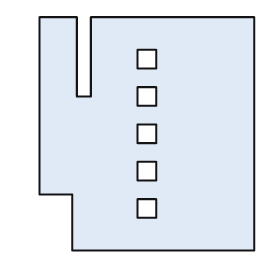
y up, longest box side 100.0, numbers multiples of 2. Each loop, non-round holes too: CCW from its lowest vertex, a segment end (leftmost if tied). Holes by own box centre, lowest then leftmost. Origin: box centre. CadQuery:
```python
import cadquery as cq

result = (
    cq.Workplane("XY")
    .moveTo(-32.0, -50.0)
    .lineTo(46.0, -50.0)
    .lineTo(46.0, 50.0)
    .lineTo(-24.0, 50.0)
    .lineTo(-24.0, 16.0)
    .lineTo(-30.0, 16.0)
    .lineTo(-30.0, 50.0)
    .lineTo(-46.0, 50.0)
    .lineTo(-46.0, -26.0)
    .lineTo(-32.0, -26.0)
    .close()
    .moveTo(-4.0, -36.0)
    .lineTo(4.0, -36.0)
    .lineTo(4.0, -28.0)
    .lineTo(-4.0, -28.0)
    .close()
    .moveTo(-4.0, -20.0)
    .lineTo(4.0, -20.0)
    .lineTo(4.0, -12.0)
    .lineTo(-4.0, -12.0)
    .close()
    .moveTo(-4.0, -4.0)
    .lineTo(4.0, -4.0)
    .lineTo(4.0, 4.0)
    .lineTo(-4.0, 4.0)
    .close()
    .moveTo(-4.0, 12.0)
    .lineTo(4.0, 12.0)
    .lineTo(4.0, 20.0)
    .lineTo(-4.0, 20.0)
    .close()
    .moveTo(-4.0, 28.0)
    .lineTo(4.0, 28.0)
    .lineTo(4.0, 36.0)
    .lineTo(-4.0, 36.0)
    .close()
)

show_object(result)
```